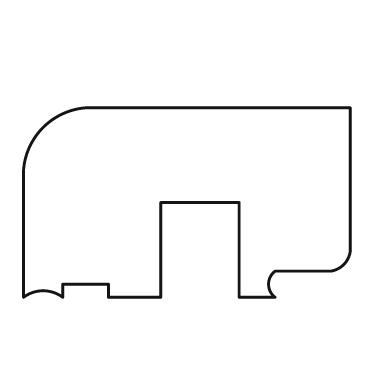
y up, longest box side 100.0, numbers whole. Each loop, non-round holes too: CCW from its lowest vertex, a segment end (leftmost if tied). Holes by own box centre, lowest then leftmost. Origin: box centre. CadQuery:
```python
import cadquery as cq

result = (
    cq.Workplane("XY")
    .moveTo(-50.0, -29.0)
    .threePointArc((-44.0, -27.0), (-38.0, -29.0))
    .lineTo(-38.0, -25.0)
    .lineTo(-24.0, -25.0)
    .lineTo(-24.0, -29.0)
    .lineTo(-8.0, -29.0)
    .lineTo(-8.0, 0.0)
    .lineTo(16.0, 0.0)
    .lineTo(16.0, -29.0)
    .lineTo(27.0, -29.0)
    .threePointArc((25.0, -25.0), (27.0, -21.0))
    .lineTo(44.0, -21.0)
    .threePointArc((48.0, -19.0), (50.0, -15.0))
    .lineTo(50.0, 29.0)
    .lineTo(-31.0, 29.0)
    .threePointArc((-44.0, 23.0), (-50.0, 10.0))
    .close()
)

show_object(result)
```